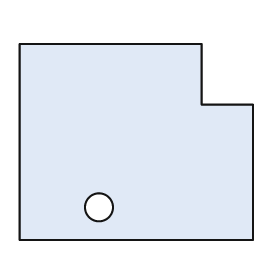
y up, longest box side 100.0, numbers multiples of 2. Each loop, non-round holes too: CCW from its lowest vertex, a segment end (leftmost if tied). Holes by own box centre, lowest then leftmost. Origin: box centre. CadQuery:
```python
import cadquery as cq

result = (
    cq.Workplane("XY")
    .moveTo(-50.0, -42.0)
    .lineTo(50.0, -42.0)
    .lineTo(50.0, 16.0)
    .lineTo(28.0, 16.0)
    .lineTo(28.0, 42.0)
    .lineTo(-50.0, 42.0)
    .close()
    .moveTo(-16.0, -28.0)
    .circle(6.0)
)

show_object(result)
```